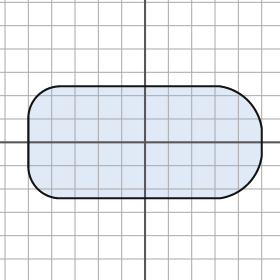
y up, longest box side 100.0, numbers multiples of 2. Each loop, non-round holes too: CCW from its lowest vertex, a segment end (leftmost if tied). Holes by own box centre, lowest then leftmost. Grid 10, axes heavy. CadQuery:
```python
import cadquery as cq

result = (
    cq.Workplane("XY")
    .moveTo(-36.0, -24.0)
    .lineTo(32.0, -24.0)
    .threePointArc((44.0, -18.0), (50.0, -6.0))
    .lineTo(50.0, 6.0)
    .threePointArc((44.0, 18.0), (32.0, 24.0))
    .lineTo(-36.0, 24.0)
    .threePointArc((-46.0, 20.0), (-50.0, 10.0))
    .lineTo(-50.0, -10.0)
    .threePointArc((-46.0, -20.0), (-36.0, -24.0))
    .close()
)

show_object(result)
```